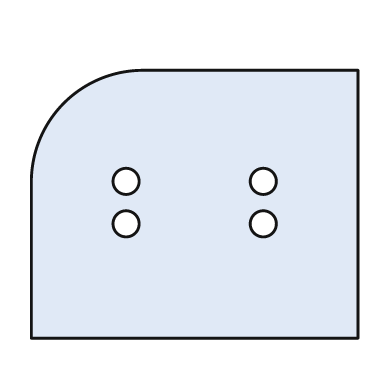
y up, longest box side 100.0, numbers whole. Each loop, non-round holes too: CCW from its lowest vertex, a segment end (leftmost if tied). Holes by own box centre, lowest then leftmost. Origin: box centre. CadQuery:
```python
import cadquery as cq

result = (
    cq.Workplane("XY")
    .moveTo(-50.0, -41.0)
    .lineTo(50.0, -41.0)
    .lineTo(50.0, 41.0)
    .lineTo(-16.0, 41.0)
    .threePointArc((-40.0, 31.0), (-50.0, 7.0))
    .close()
    .moveTo(-21.0, -6.0)
    .circle(4.0)
    .moveTo(21.0, -6.0)
    .circle(4.0)
    .moveTo(-21.0, 7.0)
    .circle(4.0)
    .moveTo(21.0, 7.0)
    .circle(4.0)
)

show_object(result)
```